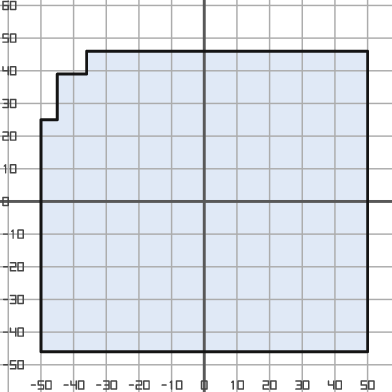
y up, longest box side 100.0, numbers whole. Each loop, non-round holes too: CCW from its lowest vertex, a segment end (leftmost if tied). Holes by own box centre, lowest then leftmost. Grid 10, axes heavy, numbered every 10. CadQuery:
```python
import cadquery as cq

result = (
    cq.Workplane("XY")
    .moveTo(-50.0, -46.0)
    .lineTo(50.0, -46.0)
    .lineTo(50.0, 46.0)
    .lineTo(-36.0, 46.0)
    .lineTo(-36.0, 39.0)
    .lineTo(-45.0, 39.0)
    .lineTo(-45.0, 25.0)
    .lineTo(-50.0, 25.0)
    .close()
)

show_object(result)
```